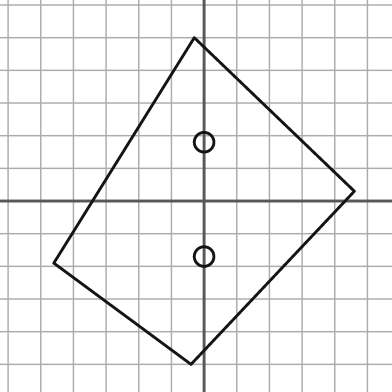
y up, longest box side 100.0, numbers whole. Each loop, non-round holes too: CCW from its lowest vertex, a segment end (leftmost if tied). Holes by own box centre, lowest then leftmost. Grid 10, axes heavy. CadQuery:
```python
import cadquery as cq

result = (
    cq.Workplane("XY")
    .moveTo(-4.0, -50.0)
    .lineTo(46.0, 3.0)
    .lineTo(-3.0, 50.0)
    .lineTo(-46.0, -19.0)
    .close()
    .moveTo(0.0, -17.0)
    .circle(3.0)
    .moveTo(0.0, 18.0)
    .circle(3.0)
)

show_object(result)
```